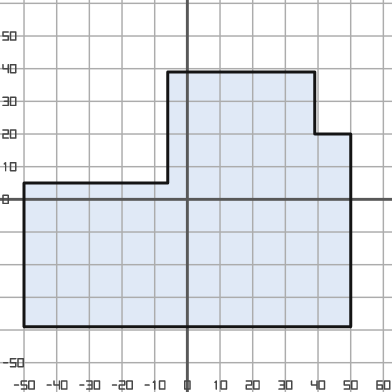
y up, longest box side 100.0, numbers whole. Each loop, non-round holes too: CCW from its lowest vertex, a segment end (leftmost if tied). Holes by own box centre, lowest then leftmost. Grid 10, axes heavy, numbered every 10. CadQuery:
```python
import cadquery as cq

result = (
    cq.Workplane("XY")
    .moveTo(-50.0, -39.0)
    .lineTo(50.0, -39.0)
    .lineTo(50.0, 20.0)
    .lineTo(39.0, 20.0)
    .lineTo(39.0, 39.0)
    .lineTo(-6.0, 39.0)
    .lineTo(-6.0, 5.0)
    .lineTo(-50.0, 5.0)
    .close()
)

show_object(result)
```